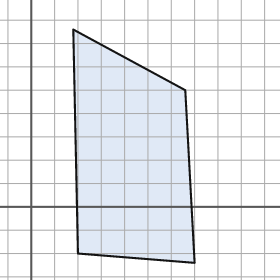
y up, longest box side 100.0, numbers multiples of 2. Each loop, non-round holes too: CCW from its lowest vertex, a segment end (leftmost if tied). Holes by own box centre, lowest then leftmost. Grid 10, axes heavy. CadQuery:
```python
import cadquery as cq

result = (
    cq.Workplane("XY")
    .moveTo(70.0, -24.0)
    .lineTo(66.0, 50.0)
    .lineTo(18.0, 76.0)
    .lineTo(20.0, -20.0)
    .close()
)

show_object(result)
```